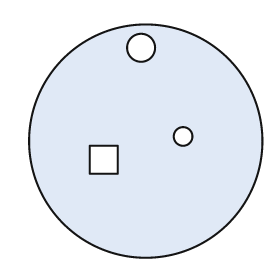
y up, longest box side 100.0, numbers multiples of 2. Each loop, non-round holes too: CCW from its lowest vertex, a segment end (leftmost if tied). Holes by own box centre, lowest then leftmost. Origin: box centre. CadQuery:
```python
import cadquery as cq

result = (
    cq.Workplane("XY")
    .moveTo(0.0, 0.0)
    .circle(50.0)
    .moveTo(-24.0, -14.0)
    .lineTo(-12.0, -14.0)
    .lineTo(-12.0, -2.0)
    .lineTo(-24.0, -2.0)
    .close()
    .moveTo(16.0, 2.0)
    .circle(4.0)
    .moveTo(-2.0, 40.0)
    .circle(6.0)
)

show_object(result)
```